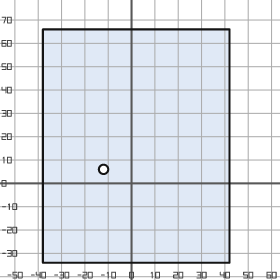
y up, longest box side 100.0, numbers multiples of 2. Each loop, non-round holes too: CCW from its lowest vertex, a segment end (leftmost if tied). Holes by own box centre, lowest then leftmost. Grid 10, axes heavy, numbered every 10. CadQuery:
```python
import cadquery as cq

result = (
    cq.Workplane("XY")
    .moveTo(-38.0, -34.0)
    .lineTo(42.0, -34.0)
    .lineTo(42.0, 66.0)
    .lineTo(-38.0, 66.0)
    .close()
    .moveTo(-12.0, 6.0)
    .circle(2.0)
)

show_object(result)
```